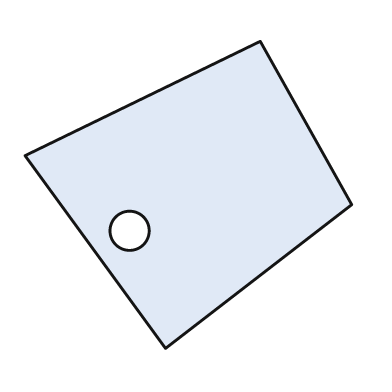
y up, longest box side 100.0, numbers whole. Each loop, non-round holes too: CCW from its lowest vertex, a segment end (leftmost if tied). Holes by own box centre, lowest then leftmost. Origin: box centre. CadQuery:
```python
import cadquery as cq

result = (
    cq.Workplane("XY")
    .moveTo(-7.0, -47.0)
    .lineTo(50.0, -3.0)
    .lineTo(22.0, 47.0)
    .lineTo(-50.0, 12.0)
    .close()
    .moveTo(-18.0, -11.0)
    .circle(6.0)
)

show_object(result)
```